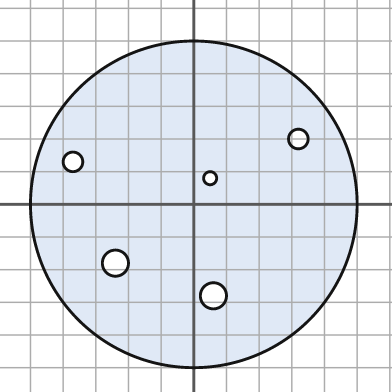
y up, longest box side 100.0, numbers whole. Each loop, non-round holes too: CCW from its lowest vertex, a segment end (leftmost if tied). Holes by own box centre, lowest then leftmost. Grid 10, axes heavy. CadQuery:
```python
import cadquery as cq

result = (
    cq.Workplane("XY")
    .moveTo(0.0, 0.0)
    .circle(50.0)
    .moveTo(6.0, -28.0)
    .circle(4.0)
    .moveTo(-24.0, -18.0)
    .circle(4.0)
    .moveTo(5.0, 8.0)
    .circle(2.0)
    .moveTo(-37.0, 13.0)
    .circle(3.0)
    .moveTo(32.0, 20.0)
    .circle(3.0)
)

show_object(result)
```